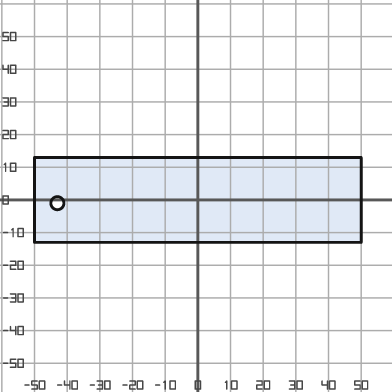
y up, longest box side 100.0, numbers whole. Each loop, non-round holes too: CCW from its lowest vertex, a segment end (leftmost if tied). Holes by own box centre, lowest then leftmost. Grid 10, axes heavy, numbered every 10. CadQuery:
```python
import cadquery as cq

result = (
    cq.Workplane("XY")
    .moveTo(-50.0, -13.0)
    .lineTo(50.0, -13.0)
    .lineTo(50.0, 13.0)
    .lineTo(-50.0, 13.0)
    .close()
    .moveTo(-43.0, -1.0)
    .circle(2.0)
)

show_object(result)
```